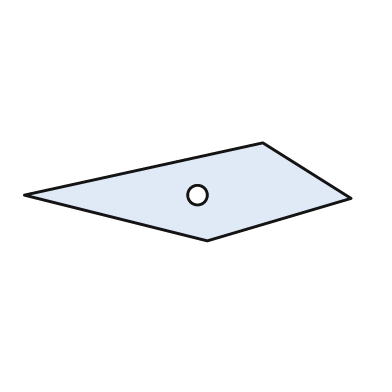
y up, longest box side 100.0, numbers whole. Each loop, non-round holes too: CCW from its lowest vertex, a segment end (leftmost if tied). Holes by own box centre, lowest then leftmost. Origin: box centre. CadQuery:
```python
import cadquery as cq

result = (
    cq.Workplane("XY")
    .moveTo(6.0, -15.0)
    .lineTo(50.0, -2.0)
    .lineTo(23.0, 15.0)
    .lineTo(-50.0, -1.0)
    .close()
    .moveTo(3.0, -1.0)
    .circle(3.0)
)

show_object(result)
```